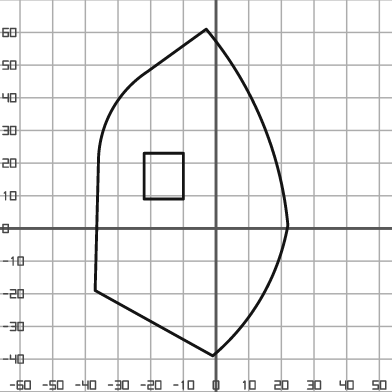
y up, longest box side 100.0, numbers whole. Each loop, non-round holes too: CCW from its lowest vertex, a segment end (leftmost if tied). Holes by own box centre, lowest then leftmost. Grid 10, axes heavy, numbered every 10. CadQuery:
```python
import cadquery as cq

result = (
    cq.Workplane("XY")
    .moveTo(-1.0, -39.0)
    .threePointArc((14.0, -21.0), (22.0, 1.0))
    .threePointArc((14.0, 33.0), (-3.0, 61.0))
    .lineTo(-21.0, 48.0)
    .threePointArc((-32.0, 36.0), (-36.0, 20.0))
    .lineTo(-37.0, -19.0)
    .close()
    .moveTo(-22.0, 9.0)
    .lineTo(-10.0, 9.0)
    .lineTo(-10.0, 23.0)
    .lineTo(-22.0, 23.0)
    .close()
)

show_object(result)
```